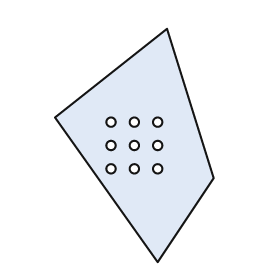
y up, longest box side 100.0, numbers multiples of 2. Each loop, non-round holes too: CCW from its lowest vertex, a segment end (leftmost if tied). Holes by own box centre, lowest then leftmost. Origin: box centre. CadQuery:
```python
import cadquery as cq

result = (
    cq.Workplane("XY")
    .moveTo(10.0, -50.0)
    .lineTo(34.0, -14.0)
    .lineTo(14.0, 50.0)
    .lineTo(-34.0, 12.0)
    .close()
    .moveTo(-10.0, -10.0)
    .circle(2.0)
    .moveTo(0.0, -10.0)
    .circle(2.0)
    .moveTo(10.0, -10.0)
    .circle(2.0)
    .moveTo(-10.0, 0.0)
    .circle(2.0)
    .moveTo(0.0, 0.0)
    .circle(2.0)
    .moveTo(10.0, 0.0)
    .circle(2.0)
    .moveTo(-10.0, 10.0)
    .circle(2.0)
    .moveTo(0.0, 10.0)
    .circle(2.0)
    .moveTo(10.0, 10.0)
    .circle(2.0)
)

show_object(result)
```